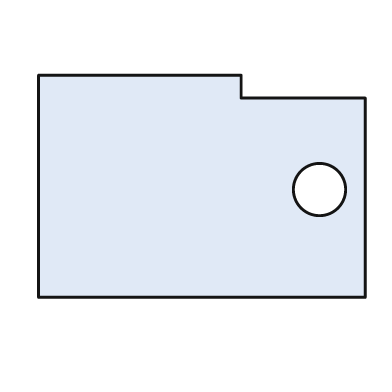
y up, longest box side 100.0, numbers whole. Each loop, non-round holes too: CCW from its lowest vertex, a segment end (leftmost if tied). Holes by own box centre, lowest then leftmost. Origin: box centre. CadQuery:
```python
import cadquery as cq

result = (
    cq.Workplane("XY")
    .moveTo(-50.0, -34.0)
    .lineTo(50.0, -34.0)
    .lineTo(50.0, 27.0)
    .lineTo(12.0, 27.0)
    .lineTo(12.0, 34.0)
    .lineTo(-50.0, 34.0)
    .close()
    .moveTo(36.0, -1.0)
    .circle(8.0)
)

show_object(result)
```